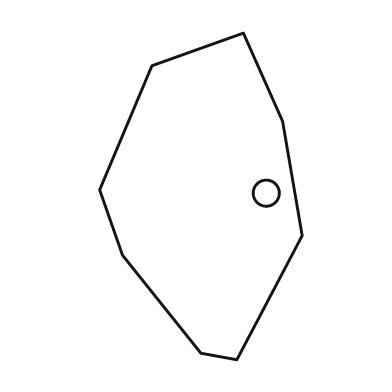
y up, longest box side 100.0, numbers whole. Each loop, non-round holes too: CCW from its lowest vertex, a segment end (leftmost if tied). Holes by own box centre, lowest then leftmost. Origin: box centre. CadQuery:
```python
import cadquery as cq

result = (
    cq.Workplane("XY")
    .moveTo(11.0, -50.0)
    .lineTo(31.0, -12.0)
    .lineTo(25.0, 23.0)
    .lineTo(13.0, 50.0)
    .lineTo(-15.0, 40.0)
    .lineTo(-31.0, 2.0)
    .lineTo(-24.0, -18.0)
    .lineTo(0.0, -48.0)
    .close()
    .moveTo(20.0, 1.0)
    .circle(4.0)
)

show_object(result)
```